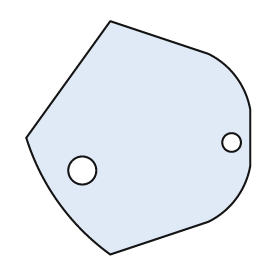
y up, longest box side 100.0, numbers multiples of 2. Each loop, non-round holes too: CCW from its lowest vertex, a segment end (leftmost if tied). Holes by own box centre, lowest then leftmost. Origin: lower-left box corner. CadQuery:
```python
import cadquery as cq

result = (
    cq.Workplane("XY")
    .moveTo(36.0, 0.0)
    .lineTo(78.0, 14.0)
    .threePointArc((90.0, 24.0), (96.0, 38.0))
    .lineTo(96.0, 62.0)
    .threePointArc((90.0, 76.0), (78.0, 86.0))
    .lineTo(36.0, 100.0)
    .lineTo(0.0, 50.0)
    .threePointArc((14.0, 22.0), (36.0, 0.0))
    .close()
    .moveTo(24.0, 36.0)
    .circle(6.0)
    .moveTo(88.0, 48.0)
    .circle(4.0)
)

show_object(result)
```